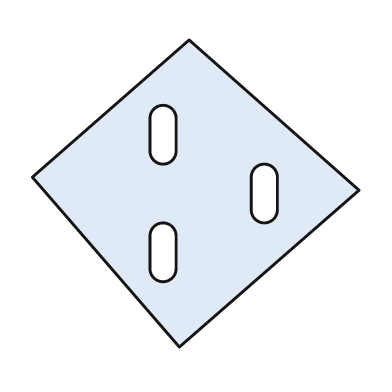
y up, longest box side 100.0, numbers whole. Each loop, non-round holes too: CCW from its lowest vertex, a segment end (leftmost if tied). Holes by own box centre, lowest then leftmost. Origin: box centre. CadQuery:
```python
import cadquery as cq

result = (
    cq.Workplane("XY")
    .moveTo(-5.0, -47.0)
    .lineTo(50.0, 1.0)
    .lineTo(-2.0, 47.0)
    .lineTo(-50.0, 5.0)
    .close()
    .moveTo(-14.0, -23.0)
    .threePointArc((-10.0, -27.0), (-6.0, -23.0))
    .lineTo(-6.0, -13.0)
    .threePointArc((-10.0, -9.0), (-14.0, -13.0))
    .close()
    .moveTo(17.0, -5.0)
    .threePointArc((21.0, -9.0), (25.0, -5.0))
    .lineTo(25.0, 5.0)
    .threePointArc((21.0, 9.0), (17.0, 5.0))
    .close()
    .moveTo(-14.0, 13.0)
    .threePointArc((-10.0, 9.0), (-6.0, 13.0))
    .lineTo(-6.0, 23.0)
    .threePointArc((-10.0, 27.0), (-14.0, 23.0))
    .close()
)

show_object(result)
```